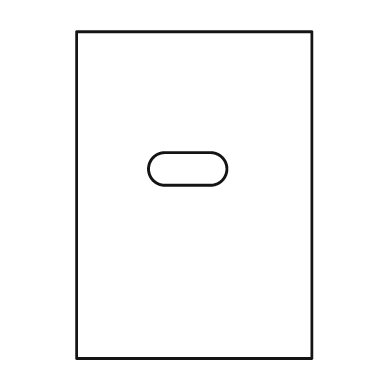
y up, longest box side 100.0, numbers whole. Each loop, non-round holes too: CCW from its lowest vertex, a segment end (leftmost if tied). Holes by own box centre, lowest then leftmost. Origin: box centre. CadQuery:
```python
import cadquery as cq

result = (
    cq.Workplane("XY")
    .moveTo(-36.0, -50.0)
    .lineTo(36.0, -50.0)
    .lineTo(36.0, 50.0)
    .lineTo(-36.0, 50.0)
    .close()
    .moveTo(-9.0, 3.0)
    .lineTo(5.0, 3.0)
    .threePointArc((10.0, 8.0), (5.0, 13.0))
    .lineTo(-9.0, 13.0)
    .threePointArc((-14.0, 8.0), (-9.0, 3.0))
    .close()
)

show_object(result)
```